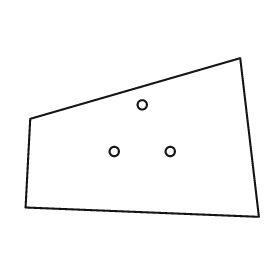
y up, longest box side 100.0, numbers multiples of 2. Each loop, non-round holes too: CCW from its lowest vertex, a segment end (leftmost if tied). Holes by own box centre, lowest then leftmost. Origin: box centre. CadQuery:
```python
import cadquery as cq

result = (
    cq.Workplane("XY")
    .moveTo(50.0, -34.0)
    .lineTo(42.0, 34.0)
    .lineTo(-48.0, 8.0)
    .lineTo(-50.0, -30.0)
    .close()
    .moveTo(-12.0, -6.0)
    .circle(2.0)
    .moveTo(12.0, -6.0)
    .circle(2.0)
    .moveTo(0.0, 14.0)
    .circle(2.0)
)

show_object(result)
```